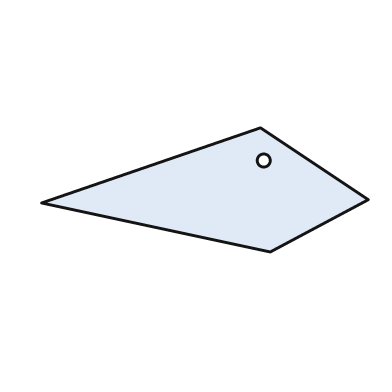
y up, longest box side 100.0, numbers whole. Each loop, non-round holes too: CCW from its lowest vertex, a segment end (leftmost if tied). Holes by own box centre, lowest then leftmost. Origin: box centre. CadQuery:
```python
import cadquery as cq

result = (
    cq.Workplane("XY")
    .moveTo(20.0, -19.0)
    .lineTo(50.0, -3.0)
    .lineTo(17.0, 19.0)
    .lineTo(-50.0, -4.0)
    .close()
    .moveTo(18.0, 9.0)
    .circle(2.0)
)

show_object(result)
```